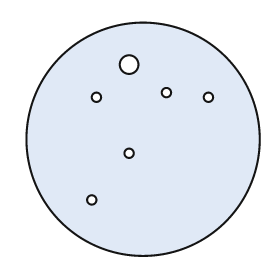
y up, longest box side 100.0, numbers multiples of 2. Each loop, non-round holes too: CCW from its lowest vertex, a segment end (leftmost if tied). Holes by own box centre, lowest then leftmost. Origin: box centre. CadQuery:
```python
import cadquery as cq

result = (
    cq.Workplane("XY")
    .moveTo(0.0, 0.0)
    .circle(50.0)
    .moveTo(-22.0, -26.0)
    .circle(2.0)
    .moveTo(-6.0, -6.0)
    .circle(2.0)
    .moveTo(-20.0, 18.0)
    .circle(2.0)
    .moveTo(28.0, 18.0)
    .circle(2.0)
    .moveTo(10.0, 20.0)
    .circle(2.0)
    .moveTo(-6.0, 32.0)
    .circle(4.0)
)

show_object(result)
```